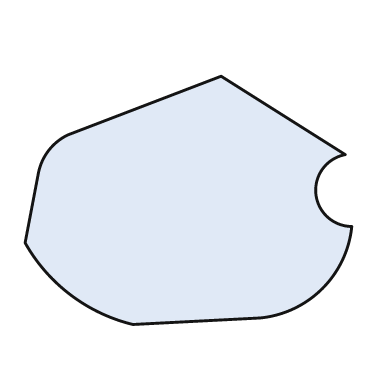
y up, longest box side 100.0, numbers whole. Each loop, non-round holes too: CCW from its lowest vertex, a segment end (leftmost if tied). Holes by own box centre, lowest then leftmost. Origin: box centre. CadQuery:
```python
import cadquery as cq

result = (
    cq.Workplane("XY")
    .moveTo(-17.0, -38.0)
    .lineTo(22.0, -36.0)
    .threePointArc((41.0, -27.0), (50.0, -8.0))
    .threePointArc((39.0, 2.0), (48.0, 14.0))
    .lineTo(10.0, 38.0)
    .lineTo(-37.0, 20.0)
    .threePointArc((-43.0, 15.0), (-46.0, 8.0))
    .lineTo(-50.0, -13.0)
    .threePointArc((-36.0, -29.0), (-17.0, -38.0))
    .close()
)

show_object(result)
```